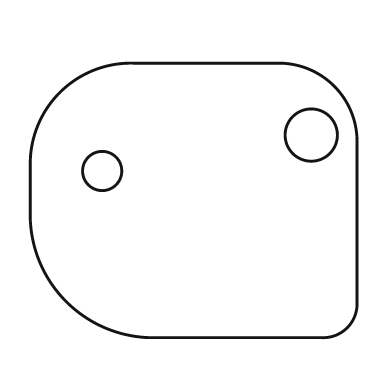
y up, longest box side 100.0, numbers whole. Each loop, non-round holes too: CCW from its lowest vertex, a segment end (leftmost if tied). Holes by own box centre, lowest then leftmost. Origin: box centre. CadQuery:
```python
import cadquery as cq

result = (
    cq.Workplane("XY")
    .moveTo(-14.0, -42.0)
    .lineTo(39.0, -42.0)
    .threePointArc((47.0, -39.0), (50.0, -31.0))
    .lineTo(50.0, 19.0)
    .threePointArc((43.0, 35.0), (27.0, 42.0))
    .lineTo(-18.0, 42.0)
    .threePointArc((-41.0, 33.0), (-50.0, 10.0))
    .lineTo(-50.0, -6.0)
    .threePointArc((-39.0, -31.0), (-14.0, -42.0))
    .close()
    .moveTo(-28.0, 9.0)
    .circle(6.0)
    .moveTo(36.0, 20.0)
    .circle(8.0)
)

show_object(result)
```